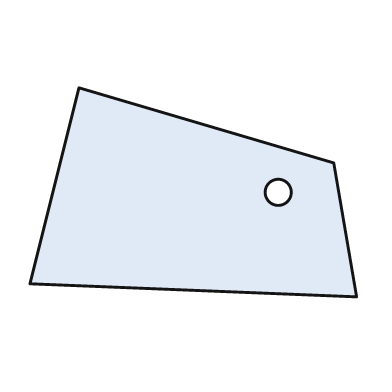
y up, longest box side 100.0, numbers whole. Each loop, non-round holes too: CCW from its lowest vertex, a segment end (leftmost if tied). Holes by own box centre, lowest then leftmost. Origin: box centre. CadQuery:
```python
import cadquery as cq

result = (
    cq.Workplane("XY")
    .moveTo(50.0, -32.0)
    .lineTo(43.0, 9.0)
    .lineTo(-35.0, 32.0)
    .lineTo(-50.0, -28.0)
    .close()
    .moveTo(26.0, 0.0)
    .circle(4.0)
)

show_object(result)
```